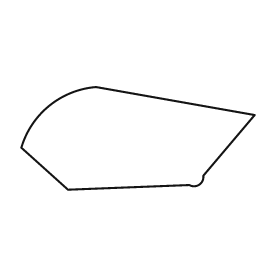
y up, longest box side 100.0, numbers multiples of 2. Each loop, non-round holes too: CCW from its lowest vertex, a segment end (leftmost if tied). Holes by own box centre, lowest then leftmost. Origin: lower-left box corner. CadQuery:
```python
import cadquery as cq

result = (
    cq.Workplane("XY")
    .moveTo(20.0, 0.0)
    .lineTo(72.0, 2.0)
    .threePointArc((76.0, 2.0), (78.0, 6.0))
    .lineTo(100.0, 32.0)
    .lineTo(32.0, 44.0)
    .threePointArc((12.0, 36.0), (0.0, 18.0))
    .close()
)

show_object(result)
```